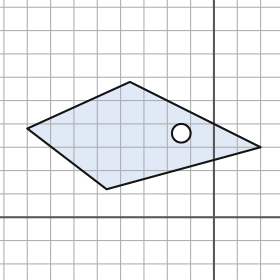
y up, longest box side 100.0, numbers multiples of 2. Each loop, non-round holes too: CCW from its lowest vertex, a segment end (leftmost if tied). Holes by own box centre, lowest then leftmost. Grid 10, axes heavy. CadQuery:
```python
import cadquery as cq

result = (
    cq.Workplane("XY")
    .moveTo(-46.0, 12.0)
    .lineTo(20.0, 30.0)
    .lineTo(-36.0, 58.0)
    .lineTo(-80.0, 38.0)
    .close()
    .moveTo(-14.0, 36.0)
    .circle(4.0)
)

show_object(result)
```